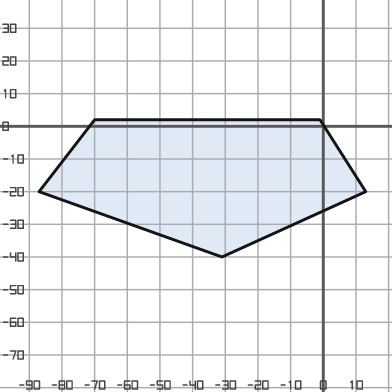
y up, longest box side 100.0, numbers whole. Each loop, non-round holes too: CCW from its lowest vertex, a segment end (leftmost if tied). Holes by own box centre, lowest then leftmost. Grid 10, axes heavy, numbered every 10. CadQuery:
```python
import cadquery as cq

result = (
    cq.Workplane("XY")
    .moveTo(-31.0, -40.0)
    .lineTo(13.0, -20.0)
    .lineTo(-1.0, 2.0)
    .lineTo(-70.0, 2.0)
    .lineTo(-87.0, -20.0)
    .close()
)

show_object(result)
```